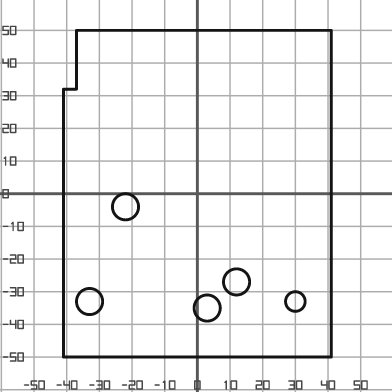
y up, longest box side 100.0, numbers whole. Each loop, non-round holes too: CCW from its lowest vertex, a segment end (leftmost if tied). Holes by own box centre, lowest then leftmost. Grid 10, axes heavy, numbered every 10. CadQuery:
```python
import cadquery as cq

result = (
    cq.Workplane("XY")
    .moveTo(-41.0, -50.0)
    .lineTo(41.0, -50.0)
    .lineTo(41.0, 50.0)
    .lineTo(-37.0, 50.0)
    .lineTo(-37.0, 32.0)
    .lineTo(-41.0, 32.0)
    .close()
    .moveTo(3.0, -35.0)
    .circle(4.0)
    .moveTo(-33.0, -33.0)
    .circle(4.0)
    .moveTo(30.0, -33.0)
    .circle(3.0)
    .moveTo(12.0, -27.0)
    .circle(4.0)
    .moveTo(-22.0, -4.0)
    .circle(4.0)
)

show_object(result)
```